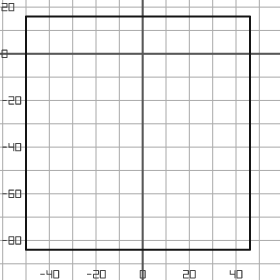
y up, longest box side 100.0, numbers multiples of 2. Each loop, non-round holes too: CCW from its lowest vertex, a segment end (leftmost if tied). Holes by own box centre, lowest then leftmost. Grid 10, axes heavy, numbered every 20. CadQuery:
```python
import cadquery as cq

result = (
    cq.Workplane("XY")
    .moveTo(-50.0, -84.0)
    .lineTo(46.0, -84.0)
    .lineTo(46.0, 16.0)
    .lineTo(-50.0, 16.0)
    .close()
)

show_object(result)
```